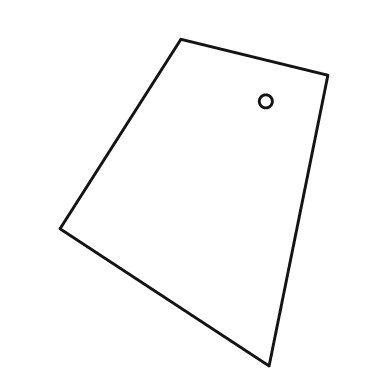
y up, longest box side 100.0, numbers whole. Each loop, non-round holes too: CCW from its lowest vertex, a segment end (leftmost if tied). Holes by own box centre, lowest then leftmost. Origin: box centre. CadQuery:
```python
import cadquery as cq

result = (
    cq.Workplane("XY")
    .moveTo(23.0, -50.0)
    .lineTo(41.0, 39.0)
    .lineTo(-4.0, 50.0)
    .lineTo(-41.0, -8.0)
    .close()
    .moveTo(22.0, 31.0)
    .circle(2.0)
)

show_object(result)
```